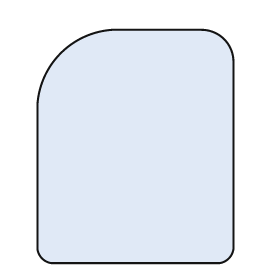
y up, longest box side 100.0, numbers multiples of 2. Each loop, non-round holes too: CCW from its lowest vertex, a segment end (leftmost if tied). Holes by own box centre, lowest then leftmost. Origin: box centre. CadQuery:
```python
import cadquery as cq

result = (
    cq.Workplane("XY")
    .moveTo(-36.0, -50.0)
    .lineTo(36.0, -50.0)
    .threePointArc((40.0, -48.0), (42.0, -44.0))
    .lineTo(42.0, 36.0)
    .threePointArc((38.0, 46.0), (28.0, 50.0))
    .lineTo(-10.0, 50.0)
    .threePointArc((-32.0, 40.0), (-42.0, 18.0))
    .lineTo(-42.0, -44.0)
    .threePointArc((-40.0, -48.0), (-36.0, -50.0))
    .close()
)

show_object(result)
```